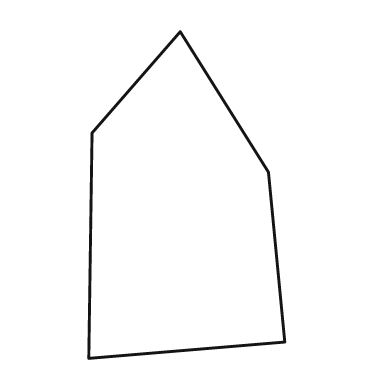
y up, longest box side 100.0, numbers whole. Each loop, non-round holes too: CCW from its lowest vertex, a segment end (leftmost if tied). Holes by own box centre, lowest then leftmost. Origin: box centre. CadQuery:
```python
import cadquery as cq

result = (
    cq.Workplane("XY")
    .moveTo(-30.0, -50.0)
    .lineTo(30.0, -45.0)
    .lineTo(25.0, 7.0)
    .lineTo(-2.0, 50.0)
    .lineTo(-29.0, 19.0)
    .close()
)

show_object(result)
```